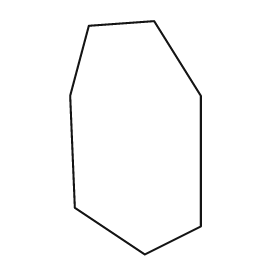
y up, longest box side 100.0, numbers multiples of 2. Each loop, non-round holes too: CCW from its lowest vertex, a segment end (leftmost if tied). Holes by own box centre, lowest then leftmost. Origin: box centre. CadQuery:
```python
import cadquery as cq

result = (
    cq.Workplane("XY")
    .moveTo(4.0, -50.0)
    .lineTo(28.0, -38.0)
    .lineTo(28.0, 18.0)
    .lineTo(8.0, 50.0)
    .lineTo(-20.0, 48.0)
    .lineTo(-28.0, 18.0)
    .lineTo(-26.0, -30.0)
    .close()
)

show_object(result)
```